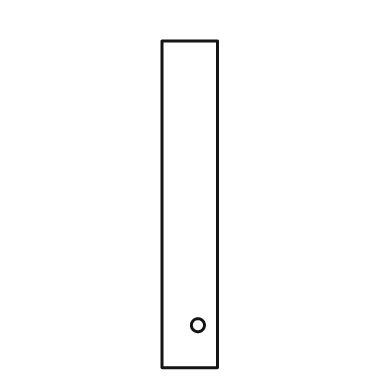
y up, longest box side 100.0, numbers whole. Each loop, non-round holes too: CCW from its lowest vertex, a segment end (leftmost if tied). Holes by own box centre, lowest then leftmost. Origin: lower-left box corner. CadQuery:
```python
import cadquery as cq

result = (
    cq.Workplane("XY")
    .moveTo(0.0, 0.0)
    .lineTo(17.0, 0.0)
    .lineTo(17.0, 100.0)
    .lineTo(0.0, 100.0)
    .close()
    .moveTo(11.0, 13.0)
    .circle(2.0)
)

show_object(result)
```